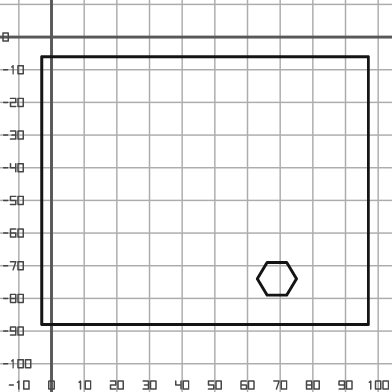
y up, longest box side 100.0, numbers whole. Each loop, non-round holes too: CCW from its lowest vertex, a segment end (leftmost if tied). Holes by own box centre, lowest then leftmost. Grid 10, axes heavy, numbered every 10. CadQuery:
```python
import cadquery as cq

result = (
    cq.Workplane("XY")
    .moveTo(-3.0, -88.0)
    .lineTo(97.0, -88.0)
    .lineTo(97.0, -6.0)
    .lineTo(-3.0, -6.0)
    .close()
    .moveTo(66.0, -79.0)
    .lineTo(72.0, -79.0)
    .lineTo(75.0, -74.0)
    .lineTo(72.0, -69.0)
    .lineTo(66.0, -69.0)
    .lineTo(63.0, -74.0)
    .close()
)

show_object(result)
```